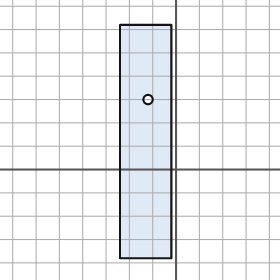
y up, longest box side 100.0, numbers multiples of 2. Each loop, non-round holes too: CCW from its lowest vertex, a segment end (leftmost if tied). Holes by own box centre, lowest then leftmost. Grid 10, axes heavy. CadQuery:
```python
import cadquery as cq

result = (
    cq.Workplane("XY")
    .moveTo(-24.0, -38.0)
    .lineTo(-2.0, -38.0)
    .lineTo(-2.0, 62.0)
    .lineTo(-24.0, 62.0)
    .close()
    .moveTo(-12.0, 30.0)
    .circle(2.0)
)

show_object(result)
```